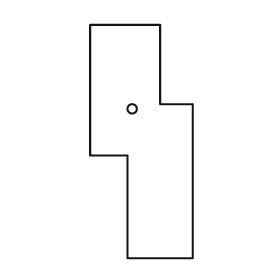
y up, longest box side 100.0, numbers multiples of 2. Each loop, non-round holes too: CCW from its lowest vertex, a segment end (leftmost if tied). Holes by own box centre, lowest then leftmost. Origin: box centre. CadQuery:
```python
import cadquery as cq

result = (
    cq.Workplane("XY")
    .moveTo(-6.0, -50.0)
    .lineTo(22.0, -50.0)
    .lineTo(22.0, 16.0)
    .lineTo(8.0, 16.0)
    .lineTo(8.0, 50.0)
    .lineTo(-22.0, 50.0)
    .lineTo(-22.0, -6.0)
    .lineTo(-6.0, -6.0)
    .close()
    .moveTo(-4.0, 14.0)
    .circle(2.0)
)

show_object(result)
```